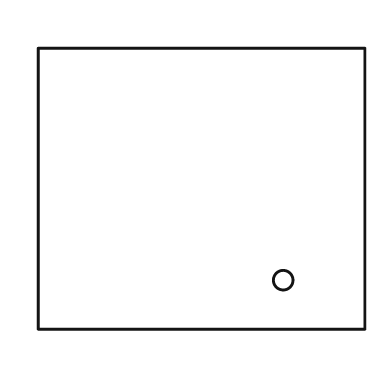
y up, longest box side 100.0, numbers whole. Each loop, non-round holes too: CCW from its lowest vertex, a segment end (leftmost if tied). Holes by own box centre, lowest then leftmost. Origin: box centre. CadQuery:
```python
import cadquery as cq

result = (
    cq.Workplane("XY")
    .moveTo(-50.0, -43.0)
    .lineTo(50.0, -43.0)
    .lineTo(50.0, 43.0)
    .lineTo(-50.0, 43.0)
    .close()
    .moveTo(25.0, -28.0)
    .circle(3.0)
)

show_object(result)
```